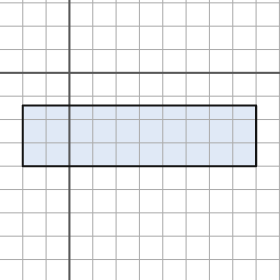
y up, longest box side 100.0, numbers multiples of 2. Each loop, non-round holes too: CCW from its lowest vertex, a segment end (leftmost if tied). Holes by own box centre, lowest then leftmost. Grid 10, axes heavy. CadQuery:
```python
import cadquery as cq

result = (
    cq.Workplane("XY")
    .moveTo(-20.0, -40.0)
    .lineTo(80.0, -40.0)
    .lineTo(80.0, -14.0)
    .lineTo(-20.0, -14.0)
    .close()
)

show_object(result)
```